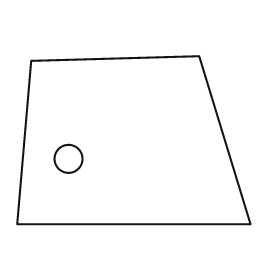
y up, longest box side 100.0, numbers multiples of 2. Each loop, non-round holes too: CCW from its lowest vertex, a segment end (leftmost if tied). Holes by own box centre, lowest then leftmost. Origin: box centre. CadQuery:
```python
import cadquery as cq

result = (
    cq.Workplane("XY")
    .moveTo(-50.0, -36.0)
    .lineTo(50.0, -36.0)
    .lineTo(28.0, 36.0)
    .lineTo(-44.0, 34.0)
    .close()
    .moveTo(-28.0, -8.0)
    .circle(6.0)
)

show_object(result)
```